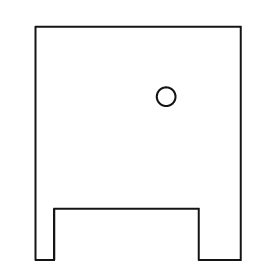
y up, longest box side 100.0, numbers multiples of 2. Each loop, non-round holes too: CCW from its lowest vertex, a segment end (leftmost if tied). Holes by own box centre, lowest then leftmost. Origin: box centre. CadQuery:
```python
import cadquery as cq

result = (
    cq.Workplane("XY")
    .moveTo(-44.0, -50.0)
    .lineTo(-36.0, -50.0)
    .lineTo(-36.0, -28.0)
    .lineTo(26.0, -28.0)
    .lineTo(26.0, -50.0)
    .lineTo(44.0, -50.0)
    .lineTo(44.0, 50.0)
    .lineTo(-44.0, 50.0)
    .close()
    .moveTo(12.0, 20.0)
    .circle(4.0)
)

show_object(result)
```